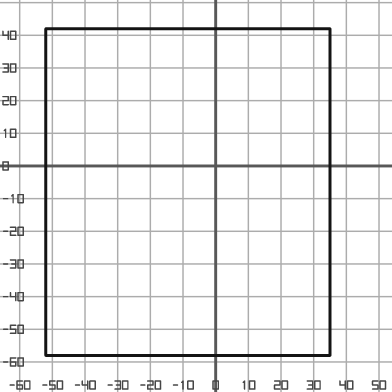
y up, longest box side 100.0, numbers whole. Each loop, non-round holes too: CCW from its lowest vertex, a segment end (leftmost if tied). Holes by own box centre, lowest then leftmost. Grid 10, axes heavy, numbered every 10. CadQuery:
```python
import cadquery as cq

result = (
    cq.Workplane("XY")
    .moveTo(-52.0, -58.0)
    .lineTo(35.0, -58.0)
    .lineTo(35.0, 42.0)
    .lineTo(-52.0, 42.0)
    .close()
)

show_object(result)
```